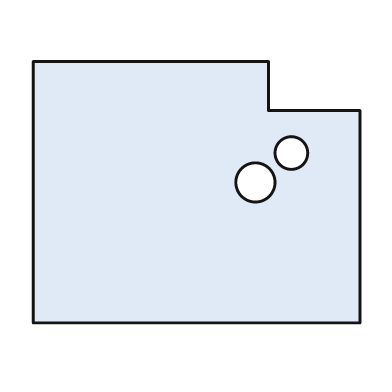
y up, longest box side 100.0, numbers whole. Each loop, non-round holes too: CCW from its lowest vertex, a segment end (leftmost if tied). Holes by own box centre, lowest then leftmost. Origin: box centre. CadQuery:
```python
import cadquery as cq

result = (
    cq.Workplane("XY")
    .moveTo(-50.0, -40.0)
    .lineTo(50.0, -40.0)
    .lineTo(50.0, 25.0)
    .lineTo(22.0, 25.0)
    .lineTo(22.0, 40.0)
    .lineTo(-50.0, 40.0)
    .close()
    .moveTo(18.0, 3.0)
    .circle(6.0)
    .moveTo(29.0, 12.0)
    .circle(5.0)
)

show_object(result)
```